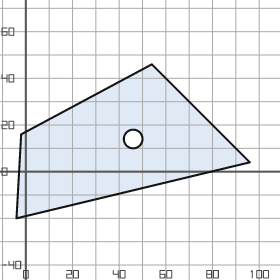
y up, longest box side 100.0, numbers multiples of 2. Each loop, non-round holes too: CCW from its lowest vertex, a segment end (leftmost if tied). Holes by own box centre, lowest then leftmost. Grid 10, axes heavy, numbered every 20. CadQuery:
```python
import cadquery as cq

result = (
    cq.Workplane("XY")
    .moveTo(-4.0, -20.0)
    .lineTo(96.0, 4.0)
    .lineTo(54.0, 46.0)
    .lineTo(-2.0, 16.0)
    .close()
    .moveTo(46.0, 14.0)
    .circle(4.0)
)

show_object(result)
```